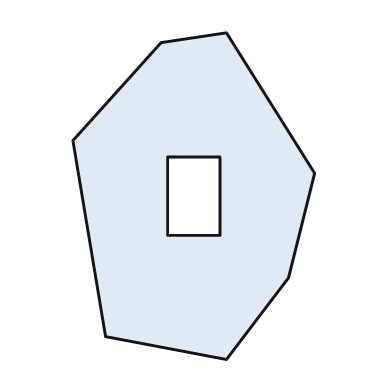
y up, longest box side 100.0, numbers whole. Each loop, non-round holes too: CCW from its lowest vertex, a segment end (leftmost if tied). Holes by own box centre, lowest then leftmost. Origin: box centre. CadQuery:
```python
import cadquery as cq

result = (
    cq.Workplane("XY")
    .moveTo(10.0, -50.0)
    .lineTo(29.0, -25.0)
    .lineTo(37.0, 7.0)
    .lineTo(10.0, 50.0)
    .lineTo(-10.0, 47.0)
    .lineTo(-37.0, 17.0)
    .lineTo(-27.0, -43.0)
    .close()
    .moveTo(-8.0, -12.0)
    .lineTo(8.0, -12.0)
    .lineTo(8.0, 12.0)
    .lineTo(-8.0, 12.0)
    .close()
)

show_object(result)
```